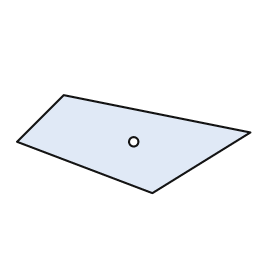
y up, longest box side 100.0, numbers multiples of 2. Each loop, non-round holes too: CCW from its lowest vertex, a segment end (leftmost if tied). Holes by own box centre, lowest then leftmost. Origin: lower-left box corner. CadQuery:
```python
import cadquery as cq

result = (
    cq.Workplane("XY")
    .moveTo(58.0, 0.0)
    .lineTo(100.0, 26.0)
    .lineTo(20.0, 42.0)
    .lineTo(0.0, 22.0)
    .close()
    .moveTo(50.0, 22.0)
    .circle(2.0)
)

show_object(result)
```